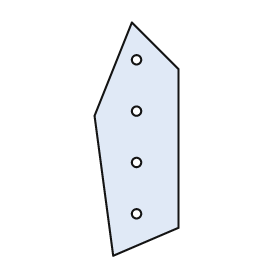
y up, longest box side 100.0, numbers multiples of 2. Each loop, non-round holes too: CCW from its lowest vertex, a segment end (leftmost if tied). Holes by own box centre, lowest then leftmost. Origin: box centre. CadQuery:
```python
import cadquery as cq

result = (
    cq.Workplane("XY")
    .moveTo(-10.0, -50.0)
    .lineTo(18.0, -38.0)
    .lineTo(18.0, 30.0)
    .lineTo(-2.0, 50.0)
    .lineTo(-18.0, 10.0)
    .close()
    .moveTo(0.0, -32.0)
    .circle(2.0)
    .moveTo(0.0, -10.0)
    .circle(2.0)
    .moveTo(0.0, 12.0)
    .circle(2.0)
    .moveTo(0.0, 34.0)
    .circle(2.0)
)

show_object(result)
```